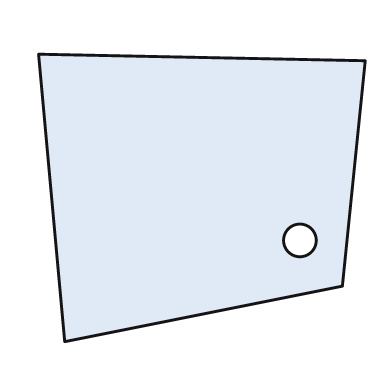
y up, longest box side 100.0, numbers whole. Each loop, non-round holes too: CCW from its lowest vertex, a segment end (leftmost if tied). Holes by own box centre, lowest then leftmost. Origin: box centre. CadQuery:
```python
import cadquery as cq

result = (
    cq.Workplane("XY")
    .moveTo(-42.0, -44.0)
    .lineTo(43.0, -27.0)
    .lineTo(50.0, 42.0)
    .lineTo(-50.0, 44.0)
    .close()
    .moveTo(30.0, -13.0)
    .circle(5.0)
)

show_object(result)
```